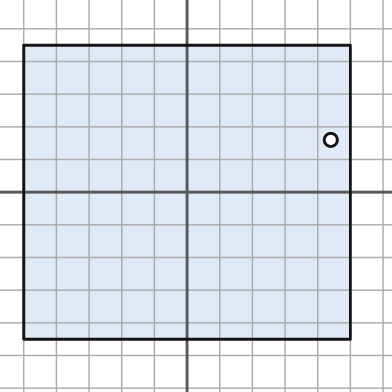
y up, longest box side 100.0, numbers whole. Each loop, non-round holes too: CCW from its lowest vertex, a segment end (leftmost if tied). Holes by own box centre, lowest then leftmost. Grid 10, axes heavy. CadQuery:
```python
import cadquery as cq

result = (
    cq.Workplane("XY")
    .moveTo(-50.0, -45.0)
    .lineTo(50.0, -45.0)
    .lineTo(50.0, 45.0)
    .lineTo(-50.0, 45.0)
    .close()
    .moveTo(44.0, 16.0)
    .circle(2.0)
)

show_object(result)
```